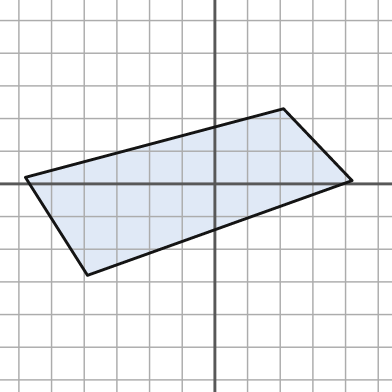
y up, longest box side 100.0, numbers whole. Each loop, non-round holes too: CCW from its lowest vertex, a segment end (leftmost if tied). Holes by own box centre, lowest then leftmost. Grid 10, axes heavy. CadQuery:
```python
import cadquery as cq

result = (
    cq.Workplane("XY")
    .moveTo(-39.0, -28.0)
    .lineTo(42.0, 1.0)
    .lineTo(21.0, 23.0)
    .lineTo(-58.0, 2.0)
    .close()
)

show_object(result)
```